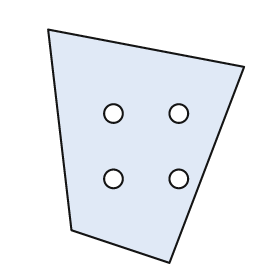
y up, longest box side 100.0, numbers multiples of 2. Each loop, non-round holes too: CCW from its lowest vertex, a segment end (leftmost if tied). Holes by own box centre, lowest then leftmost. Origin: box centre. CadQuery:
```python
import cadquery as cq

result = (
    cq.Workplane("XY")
    .moveTo(10.0, -50.0)
    .lineTo(42.0, 34.0)
    .lineTo(-42.0, 50.0)
    .lineTo(-32.0, -36.0)
    .close()
    .moveTo(-14.0, -14.0)
    .circle(4.0)
    .moveTo(14.0, -14.0)
    .circle(4.0)
    .moveTo(-14.0, 14.0)
    .circle(4.0)
    .moveTo(14.0, 14.0)
    .circle(4.0)
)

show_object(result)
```